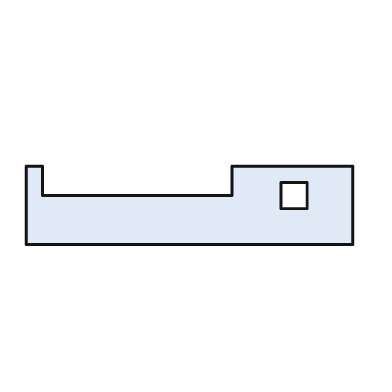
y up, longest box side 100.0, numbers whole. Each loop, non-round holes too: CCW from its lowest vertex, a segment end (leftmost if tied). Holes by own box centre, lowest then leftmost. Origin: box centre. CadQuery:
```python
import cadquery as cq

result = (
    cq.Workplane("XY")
    .moveTo(-50.0, -12.0)
    .lineTo(50.0, -12.0)
    .lineTo(50.0, 12.0)
    .lineTo(13.0, 12.0)
    .lineTo(13.0, 3.0)
    .lineTo(-45.0, 3.0)
    .lineTo(-45.0, 12.0)
    .lineTo(-50.0, 12.0)
    .close()
    .moveTo(28.0, -1.0)
    .lineTo(36.0, -1.0)
    .lineTo(36.0, 7.0)
    .lineTo(28.0, 7.0)
    .close()
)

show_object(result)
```